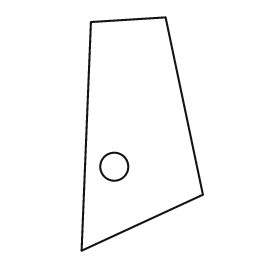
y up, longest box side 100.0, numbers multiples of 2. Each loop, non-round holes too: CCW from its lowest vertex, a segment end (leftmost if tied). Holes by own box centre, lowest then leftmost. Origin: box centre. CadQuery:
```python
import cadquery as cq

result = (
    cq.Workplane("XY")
    .moveTo(-26.0, -50.0)
    .lineTo(26.0, -26.0)
    .lineTo(10.0, 50.0)
    .lineTo(-22.0, 48.0)
    .close()
    .moveTo(-12.0, -14.0)
    .circle(6.0)
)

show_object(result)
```